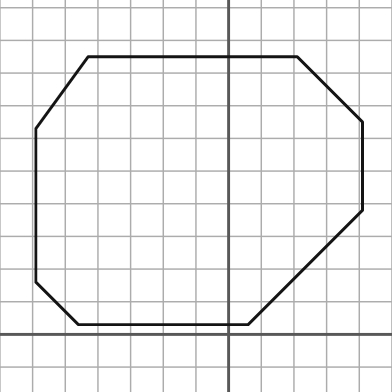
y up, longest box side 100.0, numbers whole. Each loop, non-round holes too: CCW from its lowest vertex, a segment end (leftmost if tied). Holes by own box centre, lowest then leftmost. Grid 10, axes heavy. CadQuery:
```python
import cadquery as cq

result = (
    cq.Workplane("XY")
    .moveTo(-46.0, 3.0)
    .lineTo(6.0, 3.0)
    .lineTo(41.0, 38.0)
    .lineTo(41.0, 65.0)
    .lineTo(21.0, 85.0)
    .lineTo(-43.0, 85.0)
    .lineTo(-59.0, 63.0)
    .lineTo(-59.0, 16.0)
    .close()
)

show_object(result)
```